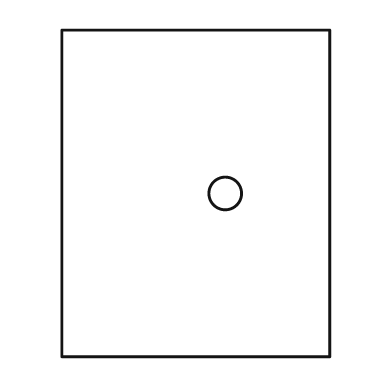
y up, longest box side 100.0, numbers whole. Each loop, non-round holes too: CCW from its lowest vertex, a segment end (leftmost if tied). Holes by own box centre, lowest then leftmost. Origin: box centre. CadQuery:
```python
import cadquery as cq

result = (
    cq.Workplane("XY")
    .moveTo(-41.0, -50.0)
    .lineTo(41.0, -50.0)
    .lineTo(41.0, 50.0)
    .lineTo(-41.0, 50.0)
    .close()
    .moveTo(9.0, 0.0)
    .circle(5.0)
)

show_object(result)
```